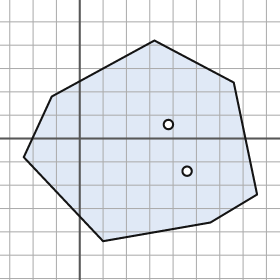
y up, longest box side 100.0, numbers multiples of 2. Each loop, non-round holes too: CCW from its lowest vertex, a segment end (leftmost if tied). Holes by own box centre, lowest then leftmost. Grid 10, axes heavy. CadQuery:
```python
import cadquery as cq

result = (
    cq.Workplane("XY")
    .moveTo(10.0, -44.0)
    .lineTo(56.0, -36.0)
    .lineTo(76.0, -24.0)
    .lineTo(66.0, 24.0)
    .lineTo(32.0, 42.0)
    .lineTo(-12.0, 18.0)
    .lineTo(-24.0, -8.0)
    .close()
    .moveTo(46.0, -14.0)
    .circle(2.0)
    .moveTo(38.0, 6.0)
    .circle(2.0)
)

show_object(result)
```